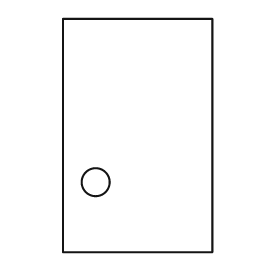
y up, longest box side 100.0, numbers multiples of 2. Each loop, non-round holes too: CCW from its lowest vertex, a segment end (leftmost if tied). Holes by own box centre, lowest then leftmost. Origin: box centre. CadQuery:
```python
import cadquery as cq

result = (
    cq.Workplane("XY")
    .moveTo(-32.0, -50.0)
    .lineTo(32.0, -50.0)
    .lineTo(32.0, 50.0)
    .lineTo(-32.0, 50.0)
    .close()
    .moveTo(-18.0, -20.0)
    .circle(6.0)
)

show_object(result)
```